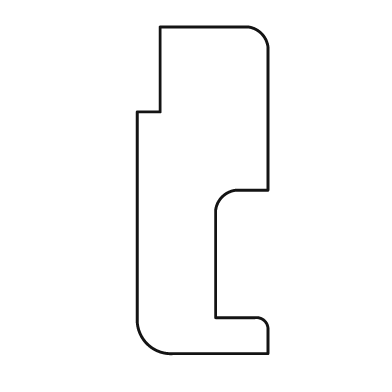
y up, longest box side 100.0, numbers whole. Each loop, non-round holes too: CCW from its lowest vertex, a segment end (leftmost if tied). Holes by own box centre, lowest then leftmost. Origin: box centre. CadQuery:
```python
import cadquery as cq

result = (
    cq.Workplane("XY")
    .moveTo(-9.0, -50.0)
    .lineTo(20.0, -50.0)
    .lineTo(20.0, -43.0)
    .threePointArc((19.0, -40.0), (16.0, -39.0))
    .lineTo(4.0, -39.0)
    .lineTo(4.0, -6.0)
    .threePointArc((6.0, -2.0), (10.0, 0.0))
    .lineTo(20.0, 0.0)
    .lineTo(20.0, 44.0)
    .threePointArc((18.0, 48.0), (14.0, 50.0))
    .lineTo(-13.0, 50.0)
    .lineTo(-13.0, 24.0)
    .lineTo(-20.0, 24.0)
    .lineTo(-20.0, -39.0)
    .threePointArc((-17.0, -47.0), (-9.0, -50.0))
    .close()
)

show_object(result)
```